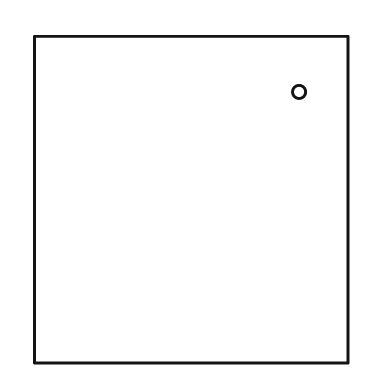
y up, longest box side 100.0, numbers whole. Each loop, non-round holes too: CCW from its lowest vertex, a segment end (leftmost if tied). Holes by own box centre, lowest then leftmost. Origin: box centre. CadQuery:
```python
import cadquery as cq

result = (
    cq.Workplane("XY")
    .moveTo(-48.0, -50.0)
    .lineTo(48.0, -50.0)
    .lineTo(48.0, 50.0)
    .lineTo(-48.0, 50.0)
    .close()
    .moveTo(33.0, 33.0)
    .circle(2.0)
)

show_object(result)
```